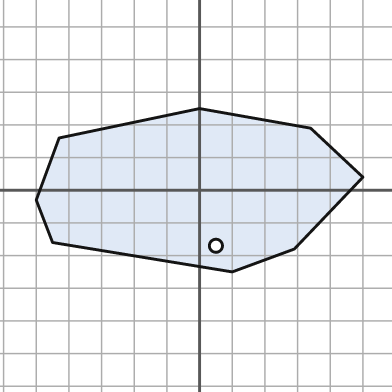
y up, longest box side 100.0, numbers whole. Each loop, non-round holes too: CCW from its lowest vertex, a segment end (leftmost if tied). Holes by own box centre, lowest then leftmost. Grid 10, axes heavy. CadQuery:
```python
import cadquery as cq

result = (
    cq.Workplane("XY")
    .moveTo(10.0, -25.0)
    .lineTo(29.0, -18.0)
    .lineTo(50.0, 4.0)
    .lineTo(34.0, 19.0)
    .lineTo(0.0, 25.0)
    .lineTo(-43.0, 16.0)
    .lineTo(-50.0, -3.0)
    .lineTo(-45.0, -16.0)
    .close()
    .moveTo(5.0, -17.0)
    .circle(2.0)
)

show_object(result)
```